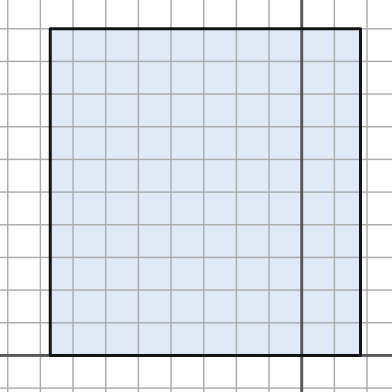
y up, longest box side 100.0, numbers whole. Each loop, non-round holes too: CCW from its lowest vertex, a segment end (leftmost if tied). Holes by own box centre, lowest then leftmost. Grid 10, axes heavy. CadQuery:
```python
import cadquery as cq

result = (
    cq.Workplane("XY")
    .moveTo(-77.0, 0.0)
    .lineTo(18.0, 0.0)
    .lineTo(18.0, 100.0)
    .lineTo(-77.0, 100.0)
    .close()
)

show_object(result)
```